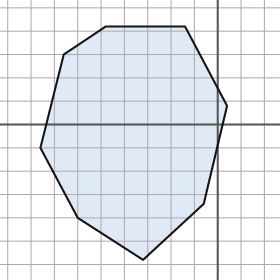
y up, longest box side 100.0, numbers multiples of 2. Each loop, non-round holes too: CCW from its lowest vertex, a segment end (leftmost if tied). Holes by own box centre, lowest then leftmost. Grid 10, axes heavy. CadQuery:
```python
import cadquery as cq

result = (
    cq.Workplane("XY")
    .moveTo(-32.0, -58.0)
    .lineTo(-6.0, -34.0)
    .lineTo(4.0, 8.0)
    .lineTo(-14.0, 42.0)
    .lineTo(-48.0, 42.0)
    .lineTo(-66.0, 30.0)
    .lineTo(-76.0, -10.0)
    .lineTo(-60.0, -40.0)
    .close()
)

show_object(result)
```